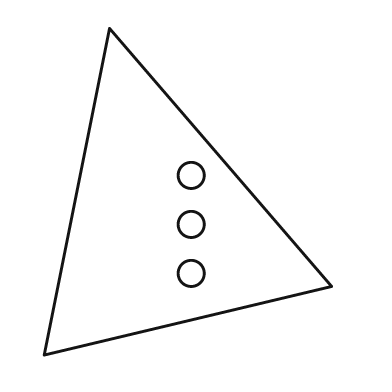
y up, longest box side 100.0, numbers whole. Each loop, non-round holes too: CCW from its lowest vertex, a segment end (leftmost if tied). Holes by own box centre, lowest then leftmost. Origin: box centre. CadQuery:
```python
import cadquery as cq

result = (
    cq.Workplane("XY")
    .moveTo(-44.0, -50.0)
    .lineTo(44.0, -29.0)
    .lineTo(-24.0, 50.0)
    .close()
    .moveTo(1.0, -25.0)
    .circle(4.0)
    .moveTo(1.0, -10.0)
    .circle(4.0)
    .moveTo(1.0, 5.0)
    .circle(4.0)
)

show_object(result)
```